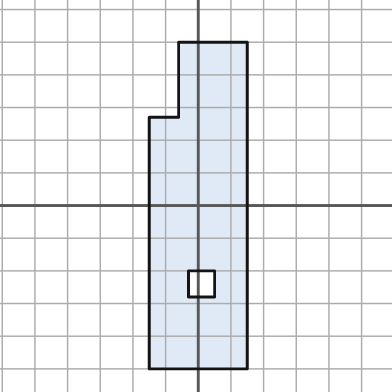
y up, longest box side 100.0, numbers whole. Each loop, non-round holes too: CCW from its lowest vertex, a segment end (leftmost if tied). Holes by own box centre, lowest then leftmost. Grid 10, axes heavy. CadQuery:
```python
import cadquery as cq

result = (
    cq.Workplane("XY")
    .moveTo(-15.0, -50.0)
    .lineTo(15.0, -50.0)
    .lineTo(15.0, 50.0)
    .lineTo(-6.0, 50.0)
    .lineTo(-6.0, 27.0)
    .lineTo(-15.0, 27.0)
    .close()
    .moveTo(-3.0, -28.0)
    .lineTo(5.0, -28.0)
    .lineTo(5.0, -20.0)
    .lineTo(-3.0, -20.0)
    .close()
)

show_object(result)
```